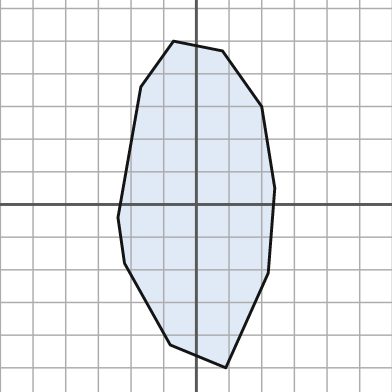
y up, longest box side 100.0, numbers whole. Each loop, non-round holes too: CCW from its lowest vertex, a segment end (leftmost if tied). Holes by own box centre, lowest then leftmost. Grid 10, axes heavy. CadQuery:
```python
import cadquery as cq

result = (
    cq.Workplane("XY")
    .moveTo(9.0, -50.0)
    .lineTo(22.0, -21.0)
    .lineTo(24.0, 5.0)
    .lineTo(20.0, 30.0)
    .lineTo(8.0, 47.0)
    .lineTo(-7.0, 50.0)
    .lineTo(-17.0, 36.0)
    .lineTo(-24.0, -4.0)
    .lineTo(-22.0, -18.0)
    .lineTo(-8.0, -43.0)
    .close()
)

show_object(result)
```